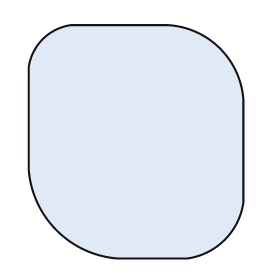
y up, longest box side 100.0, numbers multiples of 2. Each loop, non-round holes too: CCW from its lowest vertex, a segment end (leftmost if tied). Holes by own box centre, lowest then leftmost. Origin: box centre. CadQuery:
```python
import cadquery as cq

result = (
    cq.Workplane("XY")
    .moveTo(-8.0, -50.0)
    .lineTo(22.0, -50.0)
    .threePointArc((38.0, -42.0), (46.0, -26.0))
    .lineTo(46.0, 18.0)
    .threePointArc((36.0, 40.0), (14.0, 50.0))
    .lineTo(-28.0, 50.0)
    .threePointArc((-40.0, 44.0), (-46.0, 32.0))
    .lineTo(-46.0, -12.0)
    .threePointArc((-34.0, -38.0), (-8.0, -50.0))
    .close()
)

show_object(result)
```